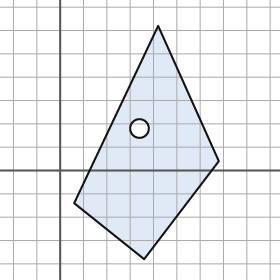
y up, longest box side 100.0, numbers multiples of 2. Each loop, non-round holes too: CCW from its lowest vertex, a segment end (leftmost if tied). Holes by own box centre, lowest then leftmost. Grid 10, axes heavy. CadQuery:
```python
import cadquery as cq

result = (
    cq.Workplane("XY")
    .moveTo(36.0, -38.0)
    .lineTo(68.0, 4.0)
    .lineTo(42.0, 62.0)
    .lineTo(6.0, -14.0)
    .close()
    .moveTo(34.0, 18.0)
    .circle(4.0)
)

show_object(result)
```